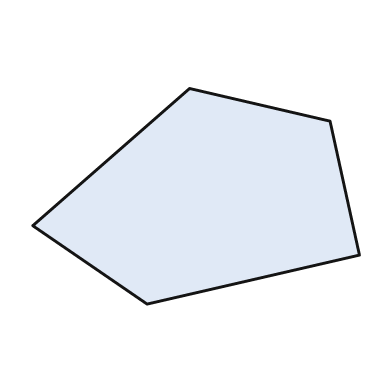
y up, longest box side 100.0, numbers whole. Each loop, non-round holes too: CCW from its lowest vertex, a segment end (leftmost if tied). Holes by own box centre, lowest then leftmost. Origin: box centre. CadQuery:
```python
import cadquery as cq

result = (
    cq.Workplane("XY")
    .moveTo(-15.0, -33.0)
    .lineTo(50.0, -18.0)
    .lineTo(41.0, 23.0)
    .lineTo(-2.0, 33.0)
    .lineTo(-50.0, -9.0)
    .close()
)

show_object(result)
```